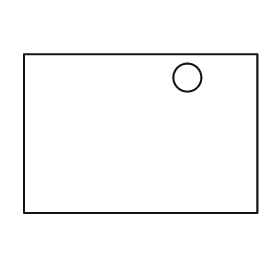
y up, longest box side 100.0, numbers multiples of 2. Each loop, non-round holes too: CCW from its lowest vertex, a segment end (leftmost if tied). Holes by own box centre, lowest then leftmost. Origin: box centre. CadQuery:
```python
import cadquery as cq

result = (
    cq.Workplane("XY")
    .moveTo(-50.0, -34.0)
    .lineTo(50.0, -34.0)
    .lineTo(50.0, 34.0)
    .lineTo(-50.0, 34.0)
    .close()
    .moveTo(20.0, 24.0)
    .circle(6.0)
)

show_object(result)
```